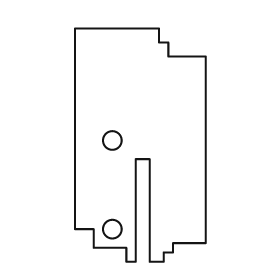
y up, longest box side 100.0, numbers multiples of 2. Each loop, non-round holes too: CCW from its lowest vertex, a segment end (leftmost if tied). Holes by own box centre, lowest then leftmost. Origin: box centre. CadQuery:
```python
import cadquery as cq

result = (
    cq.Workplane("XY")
    .moveTo(-6.0, -50.0)
    .lineTo(-2.0, -50.0)
    .lineTo(-2.0, -6.0)
    .lineTo(4.0, -6.0)
    .lineTo(4.0, -50.0)
    .lineTo(10.0, -50.0)
    .lineTo(10.0, -46.0)
    .lineTo(14.0, -46.0)
    .lineTo(14.0, -42.0)
    .lineTo(28.0, -42.0)
    .lineTo(28.0, 38.0)
    .lineTo(12.0, 38.0)
    .lineTo(12.0, 44.0)
    .lineTo(8.0, 44.0)
    .lineTo(8.0, 50.0)
    .lineTo(-28.0, 50.0)
    .lineTo(-28.0, -36.0)
    .lineTo(-20.0, -36.0)
    .lineTo(-20.0, -44.0)
    .lineTo(-6.0, -44.0)
    .close()
    .moveTo(-12.0, -36.0)
    .circle(4.0)
    .moveTo(-12.0, 2.0)
    .circle(4.0)
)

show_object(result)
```